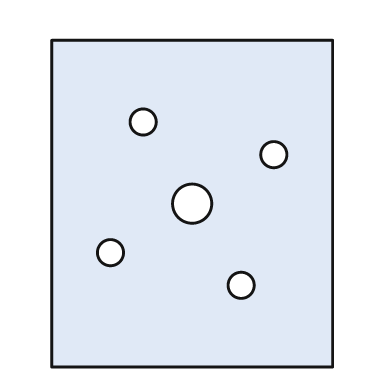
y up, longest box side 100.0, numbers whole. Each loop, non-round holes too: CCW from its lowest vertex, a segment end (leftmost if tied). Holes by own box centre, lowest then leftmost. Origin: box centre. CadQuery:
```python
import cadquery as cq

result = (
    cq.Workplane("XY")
    .moveTo(-43.0, -50.0)
    .lineTo(43.0, -50.0)
    .lineTo(43.0, 50.0)
    .lineTo(-43.0, 50.0)
    .close()
    .moveTo(15.0, -25.0)
    .circle(4.0)
    .moveTo(-25.0, -15.0)
    .circle(4.0)
    .moveTo(0.0, 0.0)
    .circle(6.0)
    .moveTo(25.0, 15.0)
    .circle(4.0)
    .moveTo(-15.0, 25.0)
    .circle(4.0)
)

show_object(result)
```